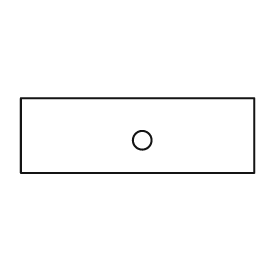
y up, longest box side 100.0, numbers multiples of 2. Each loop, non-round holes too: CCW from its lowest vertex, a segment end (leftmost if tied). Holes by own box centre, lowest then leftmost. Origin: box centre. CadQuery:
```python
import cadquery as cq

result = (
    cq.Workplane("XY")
    .moveTo(-50.0, -16.0)
    .lineTo(50.0, -16.0)
    .lineTo(50.0, 16.0)
    .lineTo(-50.0, 16.0)
    .close()
    .moveTo(2.0, -2.0)
    .circle(4.0)
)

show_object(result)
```